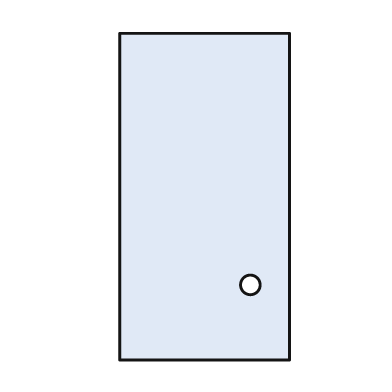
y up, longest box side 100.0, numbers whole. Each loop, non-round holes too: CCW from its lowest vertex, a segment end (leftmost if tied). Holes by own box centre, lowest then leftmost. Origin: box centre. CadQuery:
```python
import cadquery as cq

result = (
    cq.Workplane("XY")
    .moveTo(-26.0, -50.0)
    .lineTo(26.0, -50.0)
    .lineTo(26.0, 50.0)
    .lineTo(-26.0, 50.0)
    .close()
    .moveTo(14.0, -27.0)
    .circle(3.0)
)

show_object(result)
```